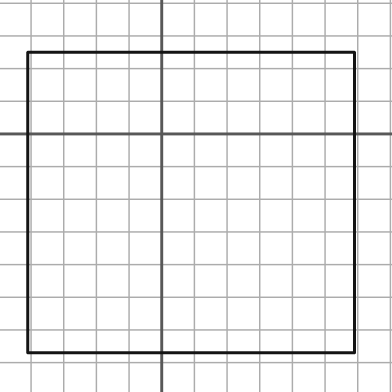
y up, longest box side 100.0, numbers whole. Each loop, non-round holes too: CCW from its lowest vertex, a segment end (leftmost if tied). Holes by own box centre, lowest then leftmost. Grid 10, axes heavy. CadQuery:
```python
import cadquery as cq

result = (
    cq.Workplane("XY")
    .moveTo(-41.0, -67.0)
    .lineTo(59.0, -67.0)
    .lineTo(59.0, 25.0)
    .lineTo(-41.0, 25.0)
    .close()
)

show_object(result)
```